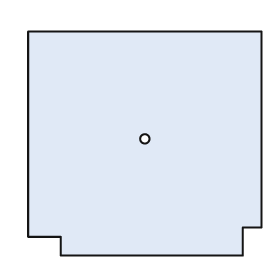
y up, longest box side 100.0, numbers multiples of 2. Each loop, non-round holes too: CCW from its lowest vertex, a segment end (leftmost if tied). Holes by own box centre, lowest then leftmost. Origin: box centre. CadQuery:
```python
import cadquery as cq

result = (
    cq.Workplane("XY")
    .moveTo(-36.0, -48.0)
    .lineTo(42.0, -48.0)
    .lineTo(42.0, -36.0)
    .lineTo(50.0, -36.0)
    .lineTo(50.0, 48.0)
    .lineTo(-50.0, 48.0)
    .lineTo(-50.0, -40.0)
    .lineTo(-36.0, -40.0)
    .close()
    .moveTo(0.0, 2.0)
    .circle(2.0)
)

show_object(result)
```